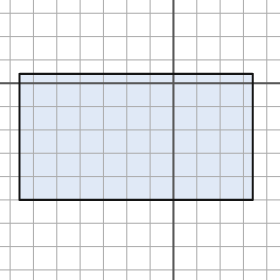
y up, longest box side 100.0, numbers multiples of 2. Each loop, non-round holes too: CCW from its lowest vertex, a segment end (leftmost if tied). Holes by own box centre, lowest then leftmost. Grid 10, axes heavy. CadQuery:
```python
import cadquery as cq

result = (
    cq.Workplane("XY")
    .moveTo(-66.0, -50.0)
    .lineTo(34.0, -50.0)
    .lineTo(34.0, 4.0)
    .lineTo(-66.0, 4.0)
    .close()
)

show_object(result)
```